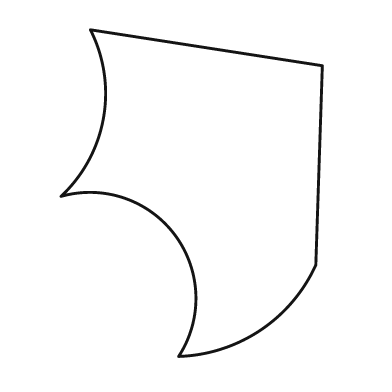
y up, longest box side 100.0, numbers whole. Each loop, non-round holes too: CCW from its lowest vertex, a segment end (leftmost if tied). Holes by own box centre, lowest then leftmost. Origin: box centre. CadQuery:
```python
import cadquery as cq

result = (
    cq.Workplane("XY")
    .moveTo(-4.0, -50.0)
    .threePointArc((21.0, -42.0), (38.0, -22.0))
    .lineTo(40.0, 39.0)
    .lineTo(-31.0, 50.0)
    .threePointArc((-27.0, 23.0), (-40.0, -1.0))
    .threePointArc((-5.0, -13.0), (-4.0, -50.0))
    .close()
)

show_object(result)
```